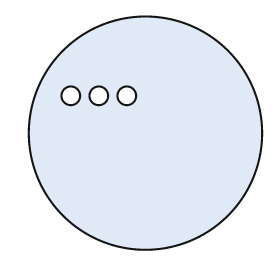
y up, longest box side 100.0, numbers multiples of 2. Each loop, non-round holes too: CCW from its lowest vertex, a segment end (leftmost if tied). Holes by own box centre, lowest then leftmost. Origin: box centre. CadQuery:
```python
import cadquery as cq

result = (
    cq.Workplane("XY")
    .moveTo(0.0, 0.0)
    .circle(50.0)
    .moveTo(-32.0, 16.0)
    .circle(4.0)
    .moveTo(-20.0, 16.0)
    .circle(4.0)
    .moveTo(-8.0, 16.0)
    .circle(4.0)
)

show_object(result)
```